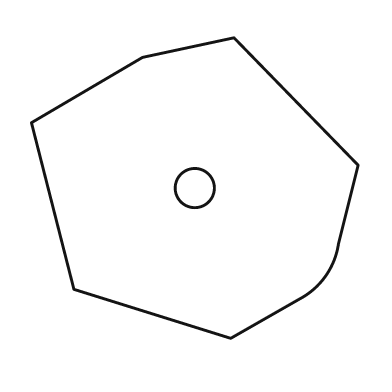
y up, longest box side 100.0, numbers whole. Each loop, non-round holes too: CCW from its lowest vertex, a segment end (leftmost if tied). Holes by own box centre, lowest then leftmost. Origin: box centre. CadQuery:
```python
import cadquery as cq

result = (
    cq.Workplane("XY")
    .moveTo(11.0, -46.0)
    .lineTo(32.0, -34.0)
    .threePointArc((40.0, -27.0), (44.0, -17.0))
    .lineTo(50.0, 7.0)
    .lineTo(12.0, 46.0)
    .lineTo(-16.0, 40.0)
    .lineTo(-50.0, 20.0)
    .lineTo(-37.0, -31.0)
    .close()
    .moveTo(0.0, 0.0)
    .circle(6.0)
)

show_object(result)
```